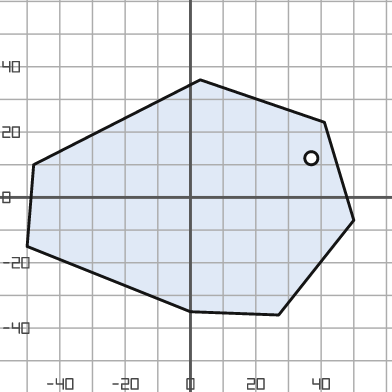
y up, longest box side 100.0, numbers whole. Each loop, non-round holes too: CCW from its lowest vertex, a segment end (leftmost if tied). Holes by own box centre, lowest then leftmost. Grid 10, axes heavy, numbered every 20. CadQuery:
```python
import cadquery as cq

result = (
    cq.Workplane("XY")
    .moveTo(27.0, -36.0)
    .lineTo(50.0, -7.0)
    .lineTo(41.0, 23.0)
    .lineTo(3.0, 36.0)
    .lineTo(-48.0, 10.0)
    .lineTo(-50.0, -15.0)
    .lineTo(0.0, -35.0)
    .close()
    .moveTo(37.0, 12.0)
    .circle(2.0)
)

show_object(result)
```